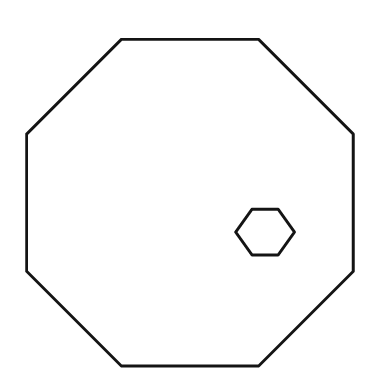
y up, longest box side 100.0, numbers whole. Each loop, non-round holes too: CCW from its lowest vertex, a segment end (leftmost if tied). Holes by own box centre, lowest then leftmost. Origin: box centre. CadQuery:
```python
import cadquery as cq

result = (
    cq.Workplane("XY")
    .moveTo(-21.0, -50.0)
    .lineTo(21.0, -50.0)
    .lineTo(50.0, -21.0)
    .lineTo(50.0, 21.0)
    .lineTo(21.0, 50.0)
    .lineTo(-21.0, 50.0)
    .lineTo(-50.0, 21.0)
    .lineTo(-50.0, -21.0)
    .close()
    .moveTo(19.0, -16.0)
    .lineTo(27.0, -16.0)
    .lineTo(32.0, -9.0)
    .lineTo(27.0, -2.0)
    .lineTo(19.0, -2.0)
    .lineTo(14.0, -9.0)
    .close()
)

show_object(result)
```